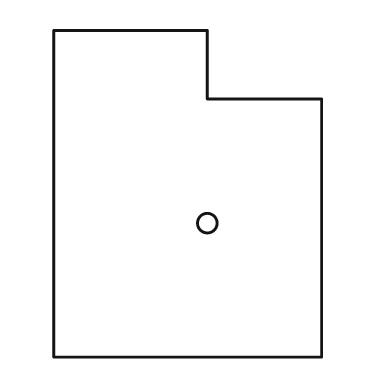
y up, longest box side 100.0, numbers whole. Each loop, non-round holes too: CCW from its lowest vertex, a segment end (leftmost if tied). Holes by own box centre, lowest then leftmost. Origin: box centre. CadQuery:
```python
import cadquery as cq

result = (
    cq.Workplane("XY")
    .moveTo(-41.0, -50.0)
    .lineTo(41.0, -50.0)
    .lineTo(41.0, 29.0)
    .lineTo(6.0, 29.0)
    .lineTo(6.0, 50.0)
    .lineTo(-41.0, 50.0)
    .close()
    .moveTo(6.0, -9.0)
    .circle(3.0)
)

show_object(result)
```